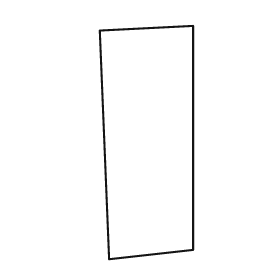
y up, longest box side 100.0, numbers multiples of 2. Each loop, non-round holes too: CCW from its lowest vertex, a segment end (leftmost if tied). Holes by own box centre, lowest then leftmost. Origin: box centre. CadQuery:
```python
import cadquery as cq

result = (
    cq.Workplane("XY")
    .moveTo(-16.0, -50.0)
    .lineTo(20.0, -46.0)
    .lineTo(20.0, 50.0)
    .lineTo(-20.0, 48.0)
    .close()
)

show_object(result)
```